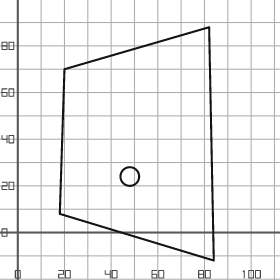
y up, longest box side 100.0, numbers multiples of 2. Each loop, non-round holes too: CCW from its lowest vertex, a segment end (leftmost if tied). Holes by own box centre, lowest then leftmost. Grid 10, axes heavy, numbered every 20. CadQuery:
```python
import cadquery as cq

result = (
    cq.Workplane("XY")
    .moveTo(84.0, -12.0)
    .lineTo(82.0, 88.0)
    .lineTo(20.0, 70.0)
    .lineTo(18.0, 8.0)
    .close()
    .moveTo(48.0, 24.0)
    .circle(4.0)
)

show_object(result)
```